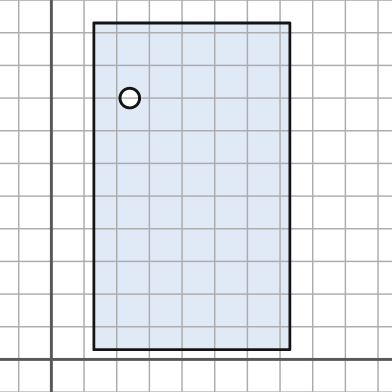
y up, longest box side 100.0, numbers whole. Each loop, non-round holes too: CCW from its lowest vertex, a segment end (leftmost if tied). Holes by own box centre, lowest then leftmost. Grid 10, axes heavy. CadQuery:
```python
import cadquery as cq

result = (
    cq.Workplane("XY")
    .moveTo(13.0, 3.0)
    .lineTo(73.0, 3.0)
    .lineTo(73.0, 103.0)
    .lineTo(13.0, 103.0)
    .close()
    .moveTo(24.0, 80.0)
    .circle(3.0)
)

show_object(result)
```